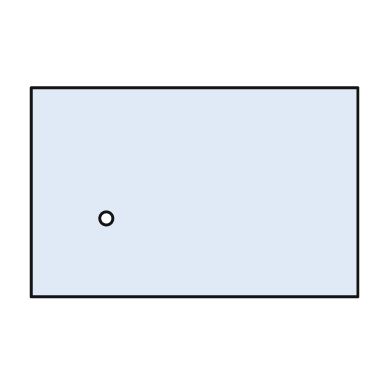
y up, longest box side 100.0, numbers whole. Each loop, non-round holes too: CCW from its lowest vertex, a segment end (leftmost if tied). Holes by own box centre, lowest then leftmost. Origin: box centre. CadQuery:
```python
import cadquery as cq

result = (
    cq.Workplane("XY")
    .moveTo(-50.0, -32.0)
    .lineTo(50.0, -32.0)
    .lineTo(50.0, 32.0)
    .lineTo(-50.0, 32.0)
    .close()
    .moveTo(-27.0, -8.0)
    .circle(2.0)
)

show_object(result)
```